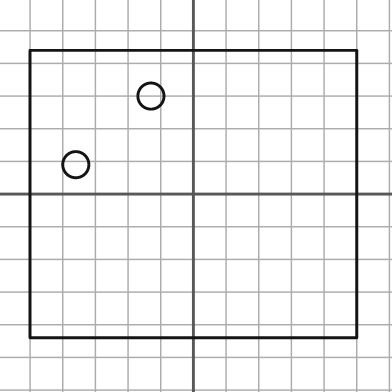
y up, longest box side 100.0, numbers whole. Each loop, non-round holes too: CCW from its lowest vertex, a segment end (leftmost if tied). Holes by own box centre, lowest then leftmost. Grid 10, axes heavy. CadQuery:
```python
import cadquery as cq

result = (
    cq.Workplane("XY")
    .moveTo(-50.0, -44.0)
    .lineTo(50.0, -44.0)
    .lineTo(50.0, 44.0)
    .lineTo(-50.0, 44.0)
    .close()
    .moveTo(-36.0, 9.0)
    .circle(4.0)
    .moveTo(-13.0, 30.0)
    .circle(4.0)
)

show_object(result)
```